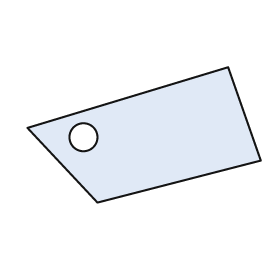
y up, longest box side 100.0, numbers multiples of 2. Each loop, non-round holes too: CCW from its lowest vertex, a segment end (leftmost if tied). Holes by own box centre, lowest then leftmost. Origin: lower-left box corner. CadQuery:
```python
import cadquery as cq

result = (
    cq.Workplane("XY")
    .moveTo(30.0, 0.0)
    .lineTo(100.0, 18.0)
    .lineTo(86.0, 58.0)
    .lineTo(0.0, 32.0)
    .close()
    .moveTo(24.0, 28.0)
    .circle(6.0)
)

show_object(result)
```